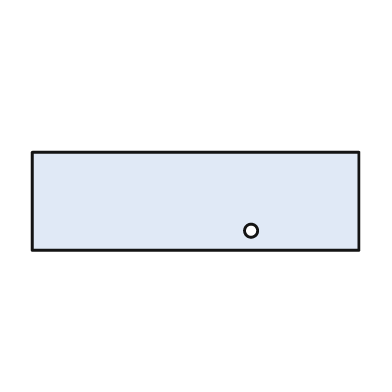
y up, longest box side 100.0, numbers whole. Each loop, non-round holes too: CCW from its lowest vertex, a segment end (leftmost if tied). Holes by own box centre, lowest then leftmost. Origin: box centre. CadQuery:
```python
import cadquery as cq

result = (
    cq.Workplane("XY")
    .moveTo(-50.0, -15.0)
    .lineTo(50.0, -15.0)
    .lineTo(50.0, 15.0)
    .lineTo(-50.0, 15.0)
    .close()
    .moveTo(17.0, -9.0)
    .circle(2.0)
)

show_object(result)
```